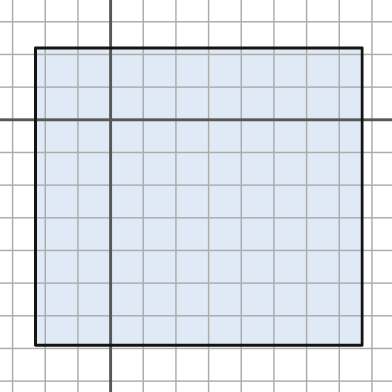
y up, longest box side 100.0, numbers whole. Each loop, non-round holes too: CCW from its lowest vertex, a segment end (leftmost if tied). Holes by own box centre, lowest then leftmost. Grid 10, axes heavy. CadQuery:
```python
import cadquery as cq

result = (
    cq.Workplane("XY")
    .moveTo(-23.0, -69.0)
    .lineTo(77.0, -69.0)
    .lineTo(77.0, 22.0)
    .lineTo(-23.0, 22.0)
    .close()
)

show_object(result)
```